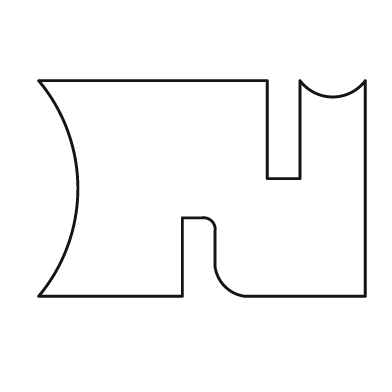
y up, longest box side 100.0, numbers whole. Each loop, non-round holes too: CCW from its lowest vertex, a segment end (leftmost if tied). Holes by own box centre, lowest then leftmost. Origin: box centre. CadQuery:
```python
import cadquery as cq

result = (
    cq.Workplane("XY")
    .moveTo(-50.0, -33.0)
    .lineTo(-6.0, -33.0)
    .lineTo(-6.0, -9.0)
    .lineTo(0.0, -9.0)
    .threePointArc((3.0, -10.0), (4.0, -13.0))
    .lineTo(4.0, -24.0)
    .threePointArc((7.0, -30.0), (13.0, -33.0))
    .lineTo(50.0, -33.0)
    .lineTo(50.0, 33.0)
    .threePointArc((40.0, 28.0), (30.0, 33.0))
    .lineTo(30.0, 3.0)
    .lineTo(20.0, 3.0)
    .lineTo(20.0, 33.0)
    .lineTo(-50.0, 33.0)
    .threePointArc((-38.0, 0.0), (-50.0, -33.0))
    .close()
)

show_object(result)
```